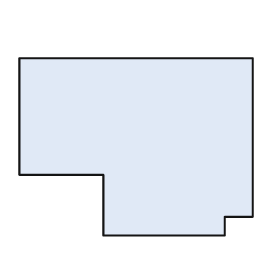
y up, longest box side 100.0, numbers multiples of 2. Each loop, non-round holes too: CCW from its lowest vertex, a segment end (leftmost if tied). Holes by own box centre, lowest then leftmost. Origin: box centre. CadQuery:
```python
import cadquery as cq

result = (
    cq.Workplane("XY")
    .moveTo(-14.0, -38.0)
    .lineTo(38.0, -38.0)
    .lineTo(38.0, -30.0)
    .lineTo(50.0, -30.0)
    .lineTo(50.0, 38.0)
    .lineTo(-50.0, 38.0)
    .lineTo(-50.0, -12.0)
    .lineTo(-14.0, -12.0)
    .close()
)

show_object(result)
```